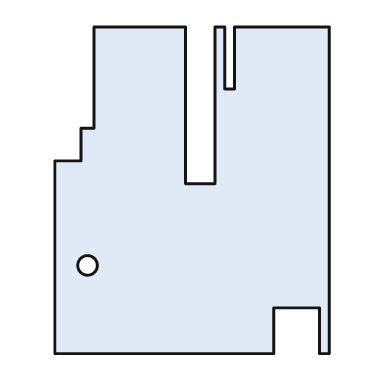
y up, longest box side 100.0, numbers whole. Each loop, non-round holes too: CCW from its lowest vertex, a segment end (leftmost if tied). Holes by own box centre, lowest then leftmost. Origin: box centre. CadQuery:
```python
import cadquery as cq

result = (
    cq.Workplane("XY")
    .moveTo(-42.0, -50.0)
    .lineTo(25.0, -50.0)
    .lineTo(25.0, -36.0)
    .lineTo(39.0, -36.0)
    .lineTo(39.0, -50.0)
    .lineTo(42.0, -50.0)
    .lineTo(42.0, 50.0)
    .lineTo(13.0, 50.0)
    .lineTo(13.0, 31.0)
    .lineTo(10.0, 31.0)
    .lineTo(10.0, 50.0)
    .lineTo(7.0, 50.0)
    .lineTo(7.0, 2.0)
    .lineTo(-2.0, 2.0)
    .lineTo(-2.0, 50.0)
    .lineTo(-30.0, 50.0)
    .lineTo(-30.0, 19.0)
    .lineTo(-34.0, 19.0)
    .lineTo(-34.0, 9.0)
    .lineTo(-42.0, 9.0)
    .close()
    .moveTo(-32.0, -23.0)
    .circle(3.0)
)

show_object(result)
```